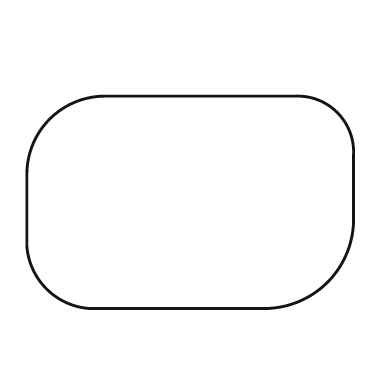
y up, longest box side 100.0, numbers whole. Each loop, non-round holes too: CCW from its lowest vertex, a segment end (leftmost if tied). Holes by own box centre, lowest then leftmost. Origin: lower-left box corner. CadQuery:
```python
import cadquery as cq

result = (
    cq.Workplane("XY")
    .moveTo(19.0, 0.0)
    .lineTo(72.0, 0.0)
    .threePointArc((92.0, 8.0), (100.0, 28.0))
    .lineTo(100.0, 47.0)
    .threePointArc((95.0, 60.0), (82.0, 65.0))
    .lineTo(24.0, 65.0)
    .threePointArc((7.0, 58.0), (0.0, 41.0))
    .lineTo(0.0, 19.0)
    .threePointArc((6.0, 6.0), (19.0, 0.0))
    .close()
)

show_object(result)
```